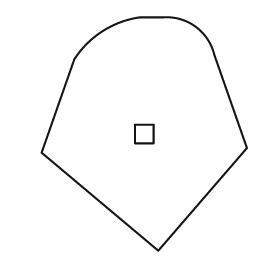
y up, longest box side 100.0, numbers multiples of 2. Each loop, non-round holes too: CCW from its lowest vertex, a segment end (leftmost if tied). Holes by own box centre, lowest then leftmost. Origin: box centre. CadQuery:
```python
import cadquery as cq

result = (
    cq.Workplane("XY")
    .moveTo(6.0, -50.0)
    .lineTo(44.0, -6.0)
    .lineTo(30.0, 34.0)
    .threePointArc((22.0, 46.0), (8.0, 50.0))
    .lineTo(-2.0, 50.0)
    .threePointArc((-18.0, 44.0), (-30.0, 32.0))
    .lineTo(-44.0, -8.0)
    .close()
    .moveTo(-4.0, -4.0)
    .lineTo(4.0, -4.0)
    .lineTo(4.0, 4.0)
    .lineTo(-4.0, 4.0)
    .close()
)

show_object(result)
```